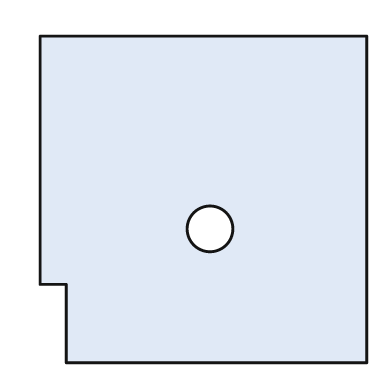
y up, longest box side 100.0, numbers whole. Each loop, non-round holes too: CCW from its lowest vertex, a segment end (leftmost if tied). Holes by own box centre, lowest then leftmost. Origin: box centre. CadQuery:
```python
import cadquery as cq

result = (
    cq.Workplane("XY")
    .moveTo(-42.0, -50.0)
    .lineTo(50.0, -50.0)
    .lineTo(50.0, 50.0)
    .lineTo(-50.0, 50.0)
    .lineTo(-50.0, -26.0)
    .lineTo(-42.0, -26.0)
    .close()
    .moveTo(2.0, -9.0)
    .circle(7.0)
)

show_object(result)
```